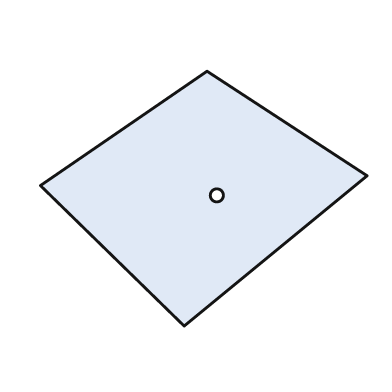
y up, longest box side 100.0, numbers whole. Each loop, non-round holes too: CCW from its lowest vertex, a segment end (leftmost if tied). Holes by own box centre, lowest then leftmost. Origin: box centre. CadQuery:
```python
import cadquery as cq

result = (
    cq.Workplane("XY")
    .moveTo(-6.0, -39.0)
    .lineTo(50.0, 7.0)
    .lineTo(1.0, 39.0)
    .lineTo(-50.0, 4.0)
    .close()
    .moveTo(4.0, 1.0)
    .circle(2.0)
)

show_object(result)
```